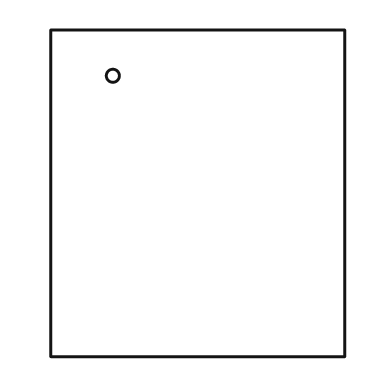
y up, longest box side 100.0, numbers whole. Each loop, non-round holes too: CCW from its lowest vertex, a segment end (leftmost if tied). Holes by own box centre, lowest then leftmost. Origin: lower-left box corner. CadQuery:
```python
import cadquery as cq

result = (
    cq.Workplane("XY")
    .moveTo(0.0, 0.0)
    .lineTo(90.0, 0.0)
    .lineTo(90.0, 100.0)
    .lineTo(0.0, 100.0)
    .close()
    .moveTo(19.0, 86.0)
    .circle(2.0)
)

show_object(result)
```